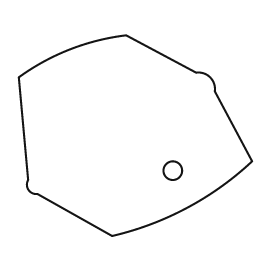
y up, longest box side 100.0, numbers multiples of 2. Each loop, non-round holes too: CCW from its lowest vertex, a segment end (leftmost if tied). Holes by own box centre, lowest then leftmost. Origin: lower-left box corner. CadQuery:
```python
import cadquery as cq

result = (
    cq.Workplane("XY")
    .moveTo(40.0, 0.0)
    .threePointArc((72.0, 12.0), (100.0, 32.0))
    .lineTo(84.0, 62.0)
    .threePointArc((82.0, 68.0), (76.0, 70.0))
    .lineTo(46.0, 86.0)
    .threePointArc((22.0, 80.0), (0.0, 68.0))
    .lineTo(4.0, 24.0)
    .threePointArc((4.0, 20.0), (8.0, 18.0))
    .close()
    .moveTo(66.0, 28.0)
    .circle(4.0)
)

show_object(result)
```